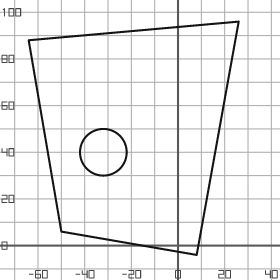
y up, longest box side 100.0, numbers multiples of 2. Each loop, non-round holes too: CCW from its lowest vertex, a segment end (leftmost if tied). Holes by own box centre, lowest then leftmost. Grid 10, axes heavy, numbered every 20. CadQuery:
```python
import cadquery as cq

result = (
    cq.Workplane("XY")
    .moveTo(8.0, -4.0)
    .lineTo(26.0, 96.0)
    .lineTo(-64.0, 88.0)
    .lineTo(-50.0, 6.0)
    .close()
    .moveTo(-32.0, 40.0)
    .circle(10.0)
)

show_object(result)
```